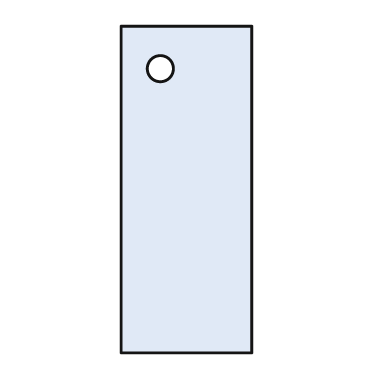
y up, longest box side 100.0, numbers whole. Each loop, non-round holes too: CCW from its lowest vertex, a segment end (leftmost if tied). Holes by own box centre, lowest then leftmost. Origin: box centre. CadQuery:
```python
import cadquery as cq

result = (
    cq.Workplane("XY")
    .moveTo(-20.0, -50.0)
    .lineTo(20.0, -50.0)
    .lineTo(20.0, 50.0)
    .lineTo(-20.0, 50.0)
    .close()
    .moveTo(-8.0, 37.0)
    .circle(4.0)
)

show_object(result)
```